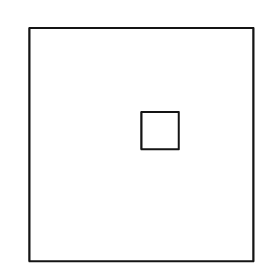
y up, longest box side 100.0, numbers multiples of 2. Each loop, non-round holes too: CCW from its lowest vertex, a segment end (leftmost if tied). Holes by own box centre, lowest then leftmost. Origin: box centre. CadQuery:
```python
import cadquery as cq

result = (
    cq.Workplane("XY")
    .moveTo(-48.0, -50.0)
    .lineTo(48.0, -50.0)
    .lineTo(48.0, 50.0)
    .lineTo(-48.0, 50.0)
    .close()
    .moveTo(0.0, -2.0)
    .lineTo(16.0, -2.0)
    .lineTo(16.0, 14.0)
    .lineTo(0.0, 14.0)
    .close()
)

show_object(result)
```